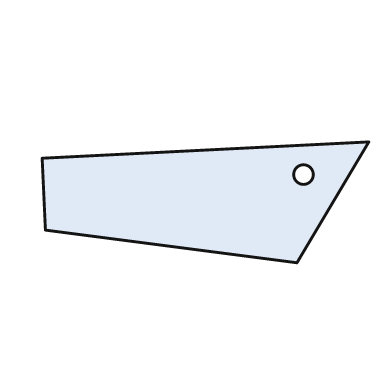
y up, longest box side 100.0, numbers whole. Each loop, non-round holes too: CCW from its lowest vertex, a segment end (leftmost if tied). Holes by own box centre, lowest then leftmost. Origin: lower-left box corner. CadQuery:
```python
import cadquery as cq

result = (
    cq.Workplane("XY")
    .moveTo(78.0, 0.0)
    .lineTo(100.0, 37.0)
    .lineTo(0.0, 32.0)
    .lineTo(1.0, 10.0)
    .close()
    .moveTo(80.0, 27.0)
    .circle(3.0)
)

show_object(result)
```